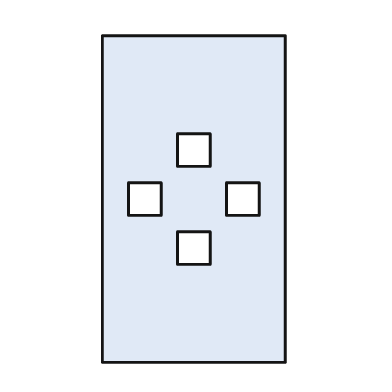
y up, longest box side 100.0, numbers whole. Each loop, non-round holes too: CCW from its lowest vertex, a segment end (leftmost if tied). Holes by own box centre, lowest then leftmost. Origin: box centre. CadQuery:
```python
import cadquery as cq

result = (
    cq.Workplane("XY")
    .moveTo(-28.0, -50.0)
    .lineTo(28.0, -50.0)
    .lineTo(28.0, 50.0)
    .lineTo(-28.0, 50.0)
    .close()
    .moveTo(-5.0, -20.0)
    .lineTo(5.0, -20.0)
    .lineTo(5.0, -10.0)
    .lineTo(-5.0, -10.0)
    .close()
    .moveTo(-20.0, -5.0)
    .lineTo(-10.0, -5.0)
    .lineTo(-10.0, 5.0)
    .lineTo(-20.0, 5.0)
    .close()
    .moveTo(10.0, -5.0)
    .lineTo(20.0, -5.0)
    .lineTo(20.0, 5.0)
    .lineTo(10.0, 5.0)
    .close()
    .moveTo(-5.0, 10.0)
    .lineTo(5.0, 10.0)
    .lineTo(5.0, 20.0)
    .lineTo(-5.0, 20.0)
    .close()
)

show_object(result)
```